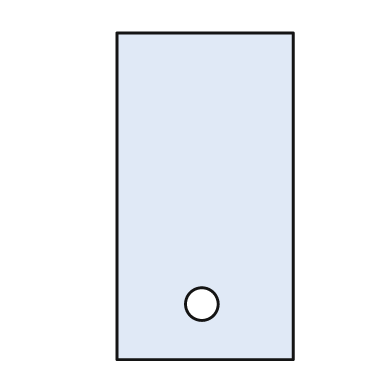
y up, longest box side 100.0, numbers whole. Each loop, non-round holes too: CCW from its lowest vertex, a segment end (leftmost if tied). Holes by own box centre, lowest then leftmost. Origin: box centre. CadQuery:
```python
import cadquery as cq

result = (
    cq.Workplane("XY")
    .moveTo(-27.0, -50.0)
    .lineTo(27.0, -50.0)
    .lineTo(27.0, 50.0)
    .lineTo(-27.0, 50.0)
    .close()
    .moveTo(-1.0, -33.0)
    .circle(5.0)
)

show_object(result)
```